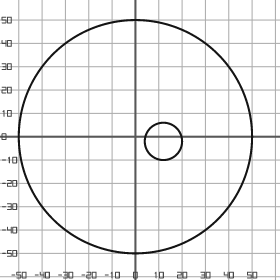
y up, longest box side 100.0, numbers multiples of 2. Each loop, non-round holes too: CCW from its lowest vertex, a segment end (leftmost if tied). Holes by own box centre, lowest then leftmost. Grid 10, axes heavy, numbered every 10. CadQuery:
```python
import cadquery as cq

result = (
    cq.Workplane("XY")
    .moveTo(0.0, 0.0)
    .circle(50.0)
    .moveTo(12.0, -2.0)
    .circle(8.0)
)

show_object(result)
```